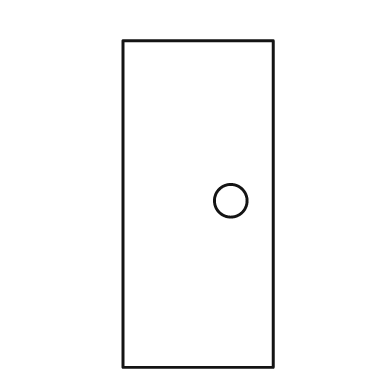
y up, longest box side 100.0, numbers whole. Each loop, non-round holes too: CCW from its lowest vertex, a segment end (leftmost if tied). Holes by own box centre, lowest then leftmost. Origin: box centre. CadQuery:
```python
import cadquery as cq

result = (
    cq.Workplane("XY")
    .moveTo(-23.0, -50.0)
    .lineTo(23.0, -50.0)
    .lineTo(23.0, 50.0)
    .lineTo(-23.0, 50.0)
    .close()
    .moveTo(10.0, 1.0)
    .circle(5.0)
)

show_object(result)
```